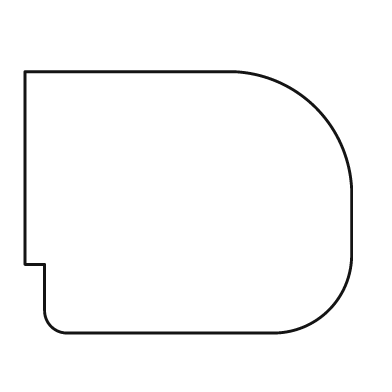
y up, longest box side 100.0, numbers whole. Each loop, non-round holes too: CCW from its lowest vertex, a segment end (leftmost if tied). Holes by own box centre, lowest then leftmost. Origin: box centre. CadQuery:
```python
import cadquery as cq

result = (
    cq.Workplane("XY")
    .moveTo(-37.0, -40.0)
    .lineTo(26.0, -40.0)
    .threePointArc((43.0, -33.0), (50.0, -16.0))
    .lineTo(50.0, 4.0)
    .threePointArc((39.0, 29.0), (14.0, 40.0))
    .lineTo(-50.0, 40.0)
    .lineTo(-50.0, -19.0)
    .lineTo(-44.0, -19.0)
    .lineTo(-44.0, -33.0)
    .threePointArc((-42.0, -38.0), (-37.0, -40.0))
    .close()
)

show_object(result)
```